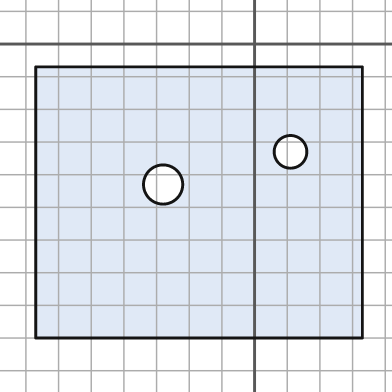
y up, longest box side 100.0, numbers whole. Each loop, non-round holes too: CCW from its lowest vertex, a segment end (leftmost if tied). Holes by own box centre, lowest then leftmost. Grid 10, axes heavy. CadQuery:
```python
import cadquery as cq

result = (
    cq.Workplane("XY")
    .moveTo(-67.0, -90.0)
    .lineTo(33.0, -90.0)
    .lineTo(33.0, -7.0)
    .lineTo(-67.0, -7.0)
    .close()
    .moveTo(-28.0, -43.0)
    .circle(6.0)
    .moveTo(11.0, -33.0)
    .circle(5.0)
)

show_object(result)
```